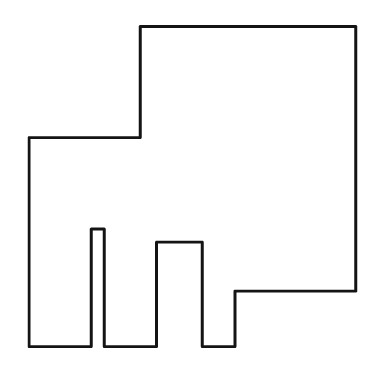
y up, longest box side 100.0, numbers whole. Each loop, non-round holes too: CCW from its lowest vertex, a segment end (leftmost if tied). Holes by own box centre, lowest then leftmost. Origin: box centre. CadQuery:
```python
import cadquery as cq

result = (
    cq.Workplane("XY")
    .moveTo(-50.0, -49.0)
    .lineTo(-31.0, -49.0)
    .lineTo(-31.0, -13.0)
    .lineTo(-27.0, -13.0)
    .lineTo(-27.0, -49.0)
    .lineTo(-11.0, -49.0)
    .lineTo(-11.0, -17.0)
    .lineTo(3.0, -17.0)
    .lineTo(3.0, -49.0)
    .lineTo(13.0, -49.0)
    .lineTo(13.0, -32.0)
    .lineTo(50.0, -32.0)
    .lineTo(50.0, 49.0)
    .lineTo(-16.0, 49.0)
    .lineTo(-16.0, 15.0)
    .lineTo(-50.0, 15.0)
    .close()
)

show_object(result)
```